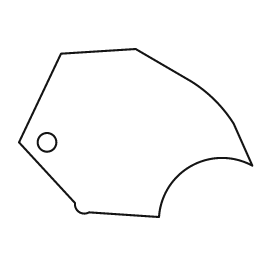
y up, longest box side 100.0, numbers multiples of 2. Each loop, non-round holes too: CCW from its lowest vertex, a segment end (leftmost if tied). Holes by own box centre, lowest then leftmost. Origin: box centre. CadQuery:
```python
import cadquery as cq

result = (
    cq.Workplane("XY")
    .moveTo(10.0, -36.0)
    .threePointArc((24.0, -14.0), (50.0, -14.0))
    .lineTo(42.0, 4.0)
    .threePointArc((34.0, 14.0), (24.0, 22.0))
    .lineTo(0.0, 36.0)
    .lineTo(-32.0, 34.0)
    .lineTo(-50.0, -4.0)
    .lineTo(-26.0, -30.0)
    .threePointArc((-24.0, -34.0), (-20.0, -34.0))
    .close()
    .moveTo(-38.0, -4.0)
    .circle(4.0)
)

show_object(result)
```